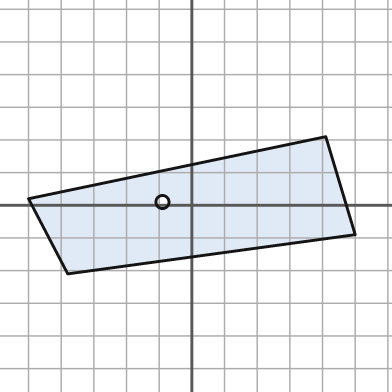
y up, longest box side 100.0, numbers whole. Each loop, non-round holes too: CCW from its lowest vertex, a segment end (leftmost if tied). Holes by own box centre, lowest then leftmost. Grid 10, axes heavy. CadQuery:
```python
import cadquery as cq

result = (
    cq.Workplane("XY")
    .moveTo(-38.0, -21.0)
    .lineTo(50.0, -9.0)
    .lineTo(41.0, 21.0)
    .lineTo(-50.0, 2.0)
    .close()
    .moveTo(-9.0, 1.0)
    .circle(2.0)
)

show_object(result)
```